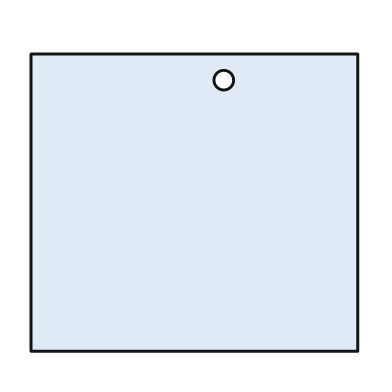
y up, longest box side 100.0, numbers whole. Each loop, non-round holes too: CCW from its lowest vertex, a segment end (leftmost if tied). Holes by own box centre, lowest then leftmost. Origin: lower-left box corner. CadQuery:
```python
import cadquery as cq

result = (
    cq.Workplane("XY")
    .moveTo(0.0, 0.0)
    .lineTo(100.0, 0.0)
    .lineTo(100.0, 91.0)
    .lineTo(0.0, 91.0)
    .close()
    .moveTo(59.0, 83.0)
    .circle(3.0)
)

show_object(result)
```